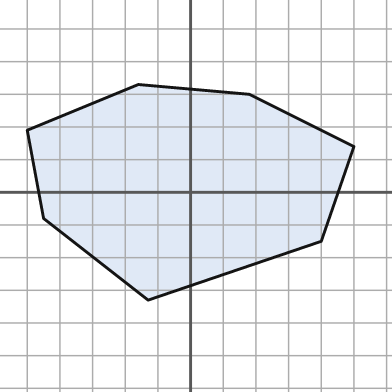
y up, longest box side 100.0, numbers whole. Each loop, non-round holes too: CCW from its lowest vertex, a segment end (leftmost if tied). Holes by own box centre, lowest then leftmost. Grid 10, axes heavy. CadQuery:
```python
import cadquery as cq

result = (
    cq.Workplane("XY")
    .moveTo(-13.0, -33.0)
    .lineTo(40.0, -15.0)
    .lineTo(50.0, 14.0)
    .lineTo(18.0, 30.0)
    .lineTo(-16.0, 33.0)
    .lineTo(-50.0, 19.0)
    .lineTo(-45.0, -8.0)
    .close()
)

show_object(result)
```